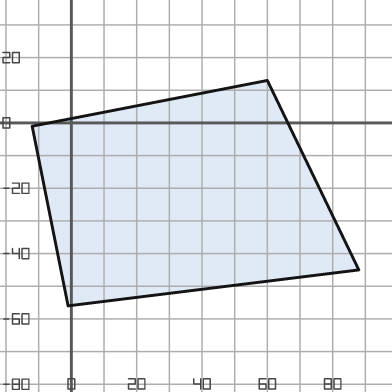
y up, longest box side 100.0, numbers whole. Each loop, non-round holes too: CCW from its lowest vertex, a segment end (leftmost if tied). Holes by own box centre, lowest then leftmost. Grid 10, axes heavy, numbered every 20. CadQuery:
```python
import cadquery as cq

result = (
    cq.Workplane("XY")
    .moveTo(-1.0, -56.0)
    .lineTo(88.0, -45.0)
    .lineTo(60.0, 13.0)
    .lineTo(-12.0, -1.0)
    .close()
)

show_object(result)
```